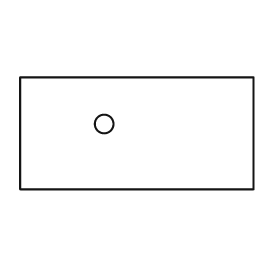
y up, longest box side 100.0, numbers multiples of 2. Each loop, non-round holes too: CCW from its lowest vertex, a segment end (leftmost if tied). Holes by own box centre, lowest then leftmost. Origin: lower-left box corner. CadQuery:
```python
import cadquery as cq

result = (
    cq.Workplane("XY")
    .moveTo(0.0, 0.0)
    .lineTo(100.0, 0.0)
    .lineTo(100.0, 48.0)
    .lineTo(0.0, 48.0)
    .close()
    .moveTo(36.0, 28.0)
    .circle(4.0)
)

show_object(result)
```